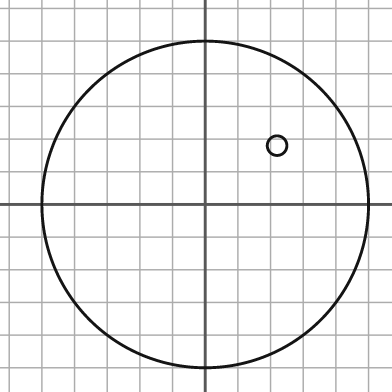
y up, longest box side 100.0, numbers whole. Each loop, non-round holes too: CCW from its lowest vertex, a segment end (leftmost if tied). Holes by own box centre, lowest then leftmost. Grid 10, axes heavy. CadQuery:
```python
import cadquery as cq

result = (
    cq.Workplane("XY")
    .moveTo(0.0, 0.0)
    .circle(50.0)
    .moveTo(22.0, 18.0)
    .circle(3.0)
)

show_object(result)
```